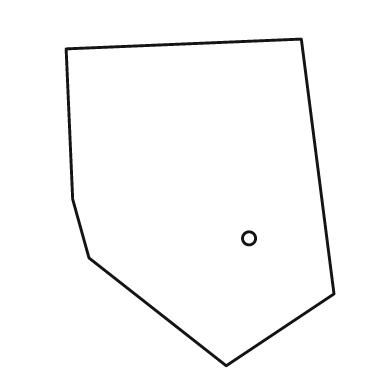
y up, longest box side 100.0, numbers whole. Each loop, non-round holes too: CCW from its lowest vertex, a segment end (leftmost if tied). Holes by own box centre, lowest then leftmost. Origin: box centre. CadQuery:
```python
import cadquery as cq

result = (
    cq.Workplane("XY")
    .moveTo(8.0, -50.0)
    .lineTo(41.0, -28.0)
    .lineTo(31.0, 50.0)
    .lineTo(-41.0, 47.0)
    .lineTo(-39.0, 1.0)
    .lineTo(-34.0, -17.0)
    .close()
    .moveTo(15.0, -11.0)
    .circle(2.0)
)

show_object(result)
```